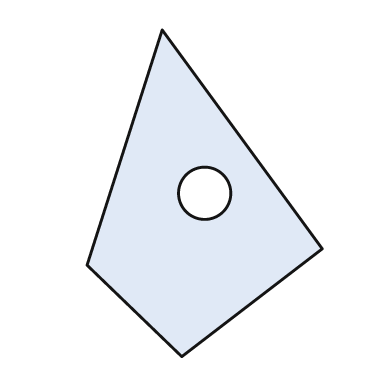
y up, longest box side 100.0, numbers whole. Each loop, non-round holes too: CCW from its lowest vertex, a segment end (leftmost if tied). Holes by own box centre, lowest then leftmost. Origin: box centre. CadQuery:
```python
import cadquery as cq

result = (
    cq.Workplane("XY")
    .moveTo(-7.0, -50.0)
    .lineTo(36.0, -17.0)
    .lineTo(-13.0, 50.0)
    .lineTo(-36.0, -22.0)
    .close()
    .moveTo(0.0, 0.0)
    .circle(8.0)
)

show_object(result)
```